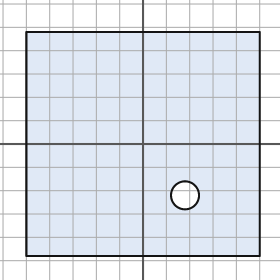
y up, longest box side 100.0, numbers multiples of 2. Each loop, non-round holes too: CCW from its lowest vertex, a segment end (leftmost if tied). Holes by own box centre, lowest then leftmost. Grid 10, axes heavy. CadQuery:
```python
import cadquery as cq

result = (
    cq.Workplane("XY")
    .moveTo(-50.0, -48.0)
    .lineTo(50.0, -48.0)
    .lineTo(50.0, 48.0)
    .lineTo(-50.0, 48.0)
    .close()
    .moveTo(18.0, -22.0)
    .circle(6.0)
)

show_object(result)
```